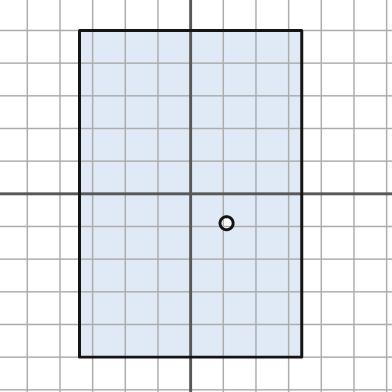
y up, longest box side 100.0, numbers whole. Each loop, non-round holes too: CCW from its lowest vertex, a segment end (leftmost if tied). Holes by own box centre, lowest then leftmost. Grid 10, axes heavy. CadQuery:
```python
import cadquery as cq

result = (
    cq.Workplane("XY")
    .moveTo(-34.0, -50.0)
    .lineTo(34.0, -50.0)
    .lineTo(34.0, 50.0)
    .lineTo(-34.0, 50.0)
    .close()
    .moveTo(11.0, -9.0)
    .circle(2.0)
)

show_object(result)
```